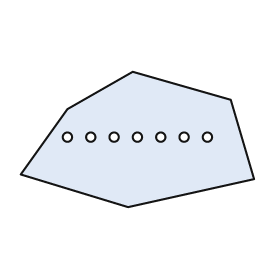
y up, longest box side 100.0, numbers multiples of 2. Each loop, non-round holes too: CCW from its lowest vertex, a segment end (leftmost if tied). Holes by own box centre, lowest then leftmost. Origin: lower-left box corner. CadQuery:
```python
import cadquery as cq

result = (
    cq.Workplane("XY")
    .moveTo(46.0, 0.0)
    .lineTo(100.0, 12.0)
    .lineTo(90.0, 46.0)
    .lineTo(48.0, 58.0)
    .lineTo(20.0, 42.0)
    .lineTo(0.0, 14.0)
    .close()
    .moveTo(20.0, 30.0)
    .circle(2.0)
    .moveTo(30.0, 30.0)
    .circle(2.0)
    .moveTo(40.0, 30.0)
    .circle(2.0)
    .moveTo(50.0, 30.0)
    .circle(2.0)
    .moveTo(60.0, 30.0)
    .circle(2.0)
    .moveTo(70.0, 30.0)
    .circle(2.0)
    .moveTo(80.0, 30.0)
    .circle(2.0)
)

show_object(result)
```